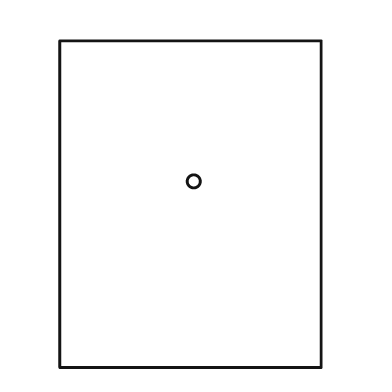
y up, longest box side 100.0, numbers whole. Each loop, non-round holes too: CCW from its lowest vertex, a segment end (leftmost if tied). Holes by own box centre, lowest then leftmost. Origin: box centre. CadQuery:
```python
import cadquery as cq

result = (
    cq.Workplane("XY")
    .moveTo(-40.0, -50.0)
    .lineTo(40.0, -50.0)
    .lineTo(40.0, 50.0)
    .lineTo(-40.0, 50.0)
    .close()
    .moveTo(1.0, 7.0)
    .circle(2.0)
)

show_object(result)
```